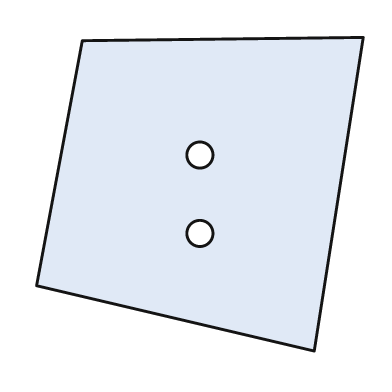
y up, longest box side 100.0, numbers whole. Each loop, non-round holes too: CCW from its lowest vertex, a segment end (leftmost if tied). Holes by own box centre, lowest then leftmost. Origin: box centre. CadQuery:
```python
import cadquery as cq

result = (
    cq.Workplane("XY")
    .moveTo(35.0, -48.0)
    .lineTo(50.0, 48.0)
    .lineTo(-36.0, 47.0)
    .lineTo(-50.0, -28.0)
    .close()
    .moveTo(0.0, -12.0)
    .circle(4.0)
    .moveTo(0.0, 12.0)
    .circle(4.0)
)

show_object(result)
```